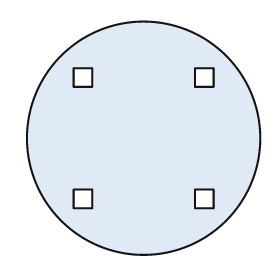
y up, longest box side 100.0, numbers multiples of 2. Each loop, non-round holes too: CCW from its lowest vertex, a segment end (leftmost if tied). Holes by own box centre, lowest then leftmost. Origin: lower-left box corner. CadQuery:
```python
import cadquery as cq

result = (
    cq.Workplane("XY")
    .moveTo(50.0, 50.0)
    .circle(50.0)
    .moveTo(20.0, 20.0)
    .lineTo(28.0, 20.0)
    .lineTo(28.0, 28.0)
    .lineTo(20.0, 28.0)
    .close()
    .moveTo(72.0, 20.0)
    .lineTo(80.0, 20.0)
    .lineTo(80.0, 28.0)
    .lineTo(72.0, 28.0)
    .close()
    .moveTo(20.0, 72.0)
    .lineTo(28.0, 72.0)
    .lineTo(28.0, 80.0)
    .lineTo(20.0, 80.0)
    .close()
    .moveTo(72.0, 72.0)
    .lineTo(80.0, 72.0)
    .lineTo(80.0, 80.0)
    .lineTo(72.0, 80.0)
    .close()
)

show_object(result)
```